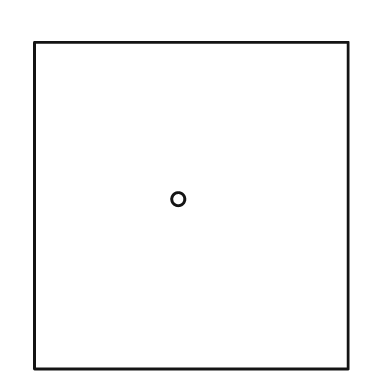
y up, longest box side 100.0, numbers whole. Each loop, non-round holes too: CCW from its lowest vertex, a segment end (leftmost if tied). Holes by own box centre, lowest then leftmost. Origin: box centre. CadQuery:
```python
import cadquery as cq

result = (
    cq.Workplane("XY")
    .moveTo(-48.0, -50.0)
    .lineTo(48.0, -50.0)
    .lineTo(48.0, 50.0)
    .lineTo(-48.0, 50.0)
    .close()
    .moveTo(-4.0, 2.0)
    .circle(2.0)
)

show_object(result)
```